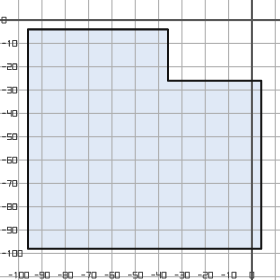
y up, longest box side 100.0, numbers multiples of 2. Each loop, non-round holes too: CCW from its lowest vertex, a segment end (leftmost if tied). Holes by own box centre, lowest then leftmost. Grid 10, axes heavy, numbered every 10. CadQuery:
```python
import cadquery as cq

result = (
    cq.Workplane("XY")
    .moveTo(-96.0, -98.0)
    .lineTo(4.0, -98.0)
    .lineTo(4.0, -26.0)
    .lineTo(-36.0, -26.0)
    .lineTo(-36.0, -4.0)
    .lineTo(-96.0, -4.0)
    .close()
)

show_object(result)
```